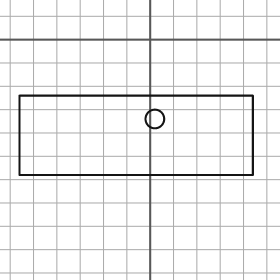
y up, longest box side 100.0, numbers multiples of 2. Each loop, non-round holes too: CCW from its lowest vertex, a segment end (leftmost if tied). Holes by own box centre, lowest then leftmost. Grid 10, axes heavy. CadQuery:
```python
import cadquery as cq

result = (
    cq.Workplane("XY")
    .moveTo(-56.0, -58.0)
    .lineTo(44.0, -58.0)
    .lineTo(44.0, -24.0)
    .lineTo(-56.0, -24.0)
    .close()
    .moveTo(2.0, -34.0)
    .circle(4.0)
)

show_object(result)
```